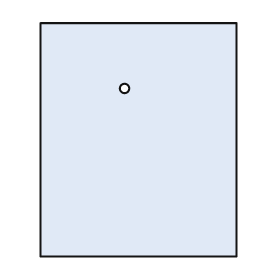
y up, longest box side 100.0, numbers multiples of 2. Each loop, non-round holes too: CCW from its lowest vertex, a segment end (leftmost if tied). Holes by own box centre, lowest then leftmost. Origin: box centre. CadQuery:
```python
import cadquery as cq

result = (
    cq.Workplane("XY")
    .moveTo(-42.0, -50.0)
    .lineTo(42.0, -50.0)
    .lineTo(42.0, 50.0)
    .lineTo(-42.0, 50.0)
    .close()
    .moveTo(-6.0, 22.0)
    .circle(2.0)
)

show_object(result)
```